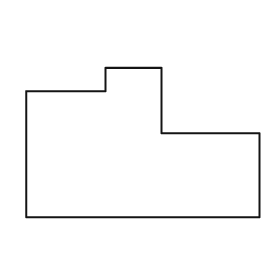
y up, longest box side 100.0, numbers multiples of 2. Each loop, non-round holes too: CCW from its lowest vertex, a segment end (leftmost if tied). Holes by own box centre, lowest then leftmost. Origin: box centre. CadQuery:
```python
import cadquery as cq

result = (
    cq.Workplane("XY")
    .moveTo(-50.0, -32.0)
    .lineTo(50.0, -32.0)
    .lineTo(50.0, 4.0)
    .lineTo(8.0, 4.0)
    .lineTo(8.0, 32.0)
    .lineTo(-16.0, 32.0)
    .lineTo(-16.0, 22.0)
    .lineTo(-50.0, 22.0)
    .close()
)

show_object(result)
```